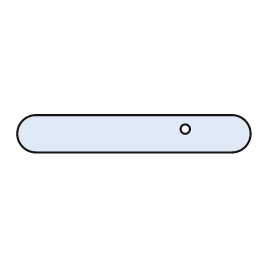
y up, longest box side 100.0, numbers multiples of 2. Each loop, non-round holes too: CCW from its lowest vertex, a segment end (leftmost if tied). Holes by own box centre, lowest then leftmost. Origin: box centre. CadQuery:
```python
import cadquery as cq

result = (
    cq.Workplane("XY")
    .moveTo(-42.0, -8.0)
    .lineTo(42.0, -8.0)
    .threePointArc((50.0, 0.0), (42.0, 8.0))
    .lineTo(-42.0, 8.0)
    .threePointArc((-50.0, 0.0), (-42.0, -8.0))
    .close()
    .moveTo(22.0, 2.0)
    .circle(2.0)
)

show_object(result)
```